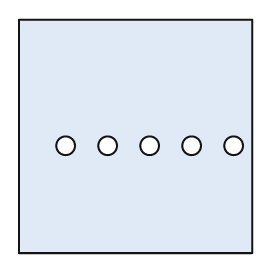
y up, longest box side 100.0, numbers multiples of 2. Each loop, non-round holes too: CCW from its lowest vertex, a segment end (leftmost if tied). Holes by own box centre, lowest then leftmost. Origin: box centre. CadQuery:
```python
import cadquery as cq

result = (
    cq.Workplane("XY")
    .moveTo(-50.0, -50.0)
    .lineTo(50.0, -50.0)
    .lineTo(50.0, 50.0)
    .lineTo(-50.0, 50.0)
    .close()
    .moveTo(-30.0, -4.0)
    .circle(4.0)
    .moveTo(-12.0, -4.0)
    .circle(4.0)
    .moveTo(6.0, -4.0)
    .circle(4.0)
    .moveTo(24.0, -4.0)
    .circle(4.0)
    .moveTo(42.0, -4.0)
    .circle(4.0)
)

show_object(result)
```